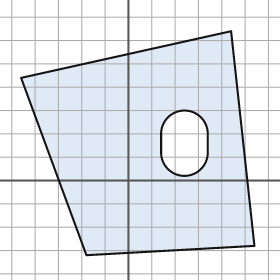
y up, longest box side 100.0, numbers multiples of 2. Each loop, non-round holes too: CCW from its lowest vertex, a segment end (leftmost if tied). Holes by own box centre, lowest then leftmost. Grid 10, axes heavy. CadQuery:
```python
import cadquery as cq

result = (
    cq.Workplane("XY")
    .moveTo(-18.0, -32.0)
    .lineTo(54.0, -28.0)
    .lineTo(44.0, 64.0)
    .lineTo(-46.0, 44.0)
    .close()
    .moveTo(14.0, 12.0)
    .threePointArc((24.0, 2.0), (34.0, 12.0))
    .lineTo(34.0, 20.0)
    .threePointArc((24.0, 30.0), (14.0, 20.0))
    .close()
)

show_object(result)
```